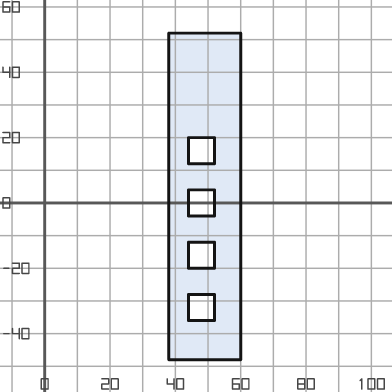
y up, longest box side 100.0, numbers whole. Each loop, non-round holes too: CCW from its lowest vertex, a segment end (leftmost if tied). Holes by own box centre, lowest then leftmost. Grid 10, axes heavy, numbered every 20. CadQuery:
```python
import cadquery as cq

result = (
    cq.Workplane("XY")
    .moveTo(38.0, -48.0)
    .lineTo(60.0, -48.0)
    .lineTo(60.0, 52.0)
    .lineTo(38.0, 52.0)
    .close()
    .moveTo(44.0, -36.0)
    .lineTo(52.0, -36.0)
    .lineTo(52.0, -28.0)
    .lineTo(44.0, -28.0)
    .close()
    .moveTo(44.0, -20.0)
    .lineTo(52.0, -20.0)
    .lineTo(52.0, -12.0)
    .lineTo(44.0, -12.0)
    .close()
    .moveTo(44.0, -4.0)
    .lineTo(52.0, -4.0)
    .lineTo(52.0, 4.0)
    .lineTo(44.0, 4.0)
    .close()
    .moveTo(44.0, 12.0)
    .lineTo(52.0, 12.0)
    .lineTo(52.0, 20.0)
    .lineTo(44.0, 20.0)
    .close()
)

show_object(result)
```